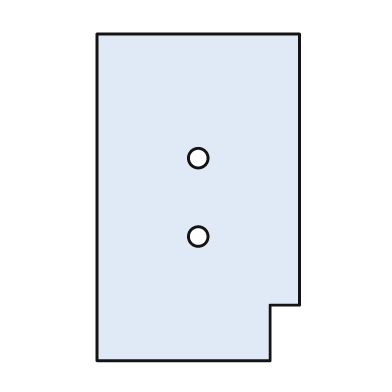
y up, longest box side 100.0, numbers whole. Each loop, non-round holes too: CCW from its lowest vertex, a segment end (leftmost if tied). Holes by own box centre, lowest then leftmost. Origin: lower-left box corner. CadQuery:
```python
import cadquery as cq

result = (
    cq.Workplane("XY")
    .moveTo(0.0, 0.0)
    .lineTo(53.0, 0.0)
    .lineTo(53.0, 17.0)
    .lineTo(62.0, 17.0)
    .lineTo(62.0, 100.0)
    .lineTo(0.0, 100.0)
    .close()
    .moveTo(31.0, 38.0)
    .circle(3.0)
    .moveTo(31.0, 62.0)
    .circle(3.0)
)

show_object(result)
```